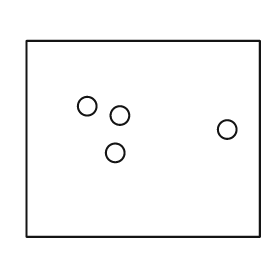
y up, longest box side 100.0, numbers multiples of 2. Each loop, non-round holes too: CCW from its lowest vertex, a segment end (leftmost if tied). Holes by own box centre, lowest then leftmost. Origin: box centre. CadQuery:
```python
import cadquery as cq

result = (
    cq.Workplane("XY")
    .moveTo(-50.0, -42.0)
    .lineTo(50.0, -42.0)
    .lineTo(50.0, 42.0)
    .lineTo(-50.0, 42.0)
    .close()
    .moveTo(-12.0, -6.0)
    .circle(4.0)
    .moveTo(36.0, 4.0)
    .circle(4.0)
    .moveTo(-10.0, 10.0)
    .circle(4.0)
    .moveTo(-24.0, 14.0)
    .circle(4.0)
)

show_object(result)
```